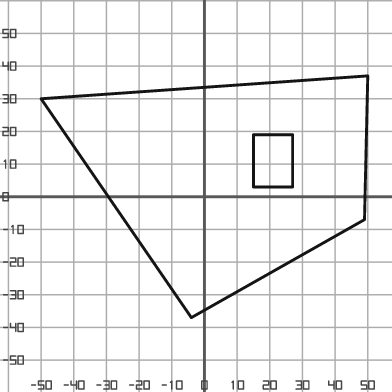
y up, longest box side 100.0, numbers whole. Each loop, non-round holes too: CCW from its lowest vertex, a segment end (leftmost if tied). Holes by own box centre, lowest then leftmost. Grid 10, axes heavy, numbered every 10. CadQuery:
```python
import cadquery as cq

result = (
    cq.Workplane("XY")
    .moveTo(-4.0, -37.0)
    .lineTo(49.0, -7.0)
    .lineTo(50.0, 37.0)
    .lineTo(-50.0, 30.0)
    .close()
    .moveTo(15.0, 3.0)
    .lineTo(27.0, 3.0)
    .lineTo(27.0, 19.0)
    .lineTo(15.0, 19.0)
    .close()
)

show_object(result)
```